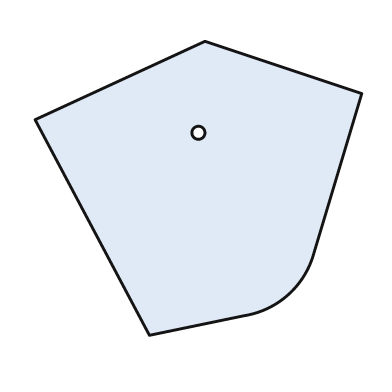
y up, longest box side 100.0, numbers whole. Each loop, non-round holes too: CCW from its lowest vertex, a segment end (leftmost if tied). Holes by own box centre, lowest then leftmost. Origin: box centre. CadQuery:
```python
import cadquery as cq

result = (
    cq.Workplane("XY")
    .moveTo(-15.0, -45.0)
    .lineTo(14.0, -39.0)
    .threePointArc((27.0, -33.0), (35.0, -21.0))
    .lineTo(50.0, 29.0)
    .lineTo(2.0, 45.0)
    .lineTo(-50.0, 21.0)
    .close()
    .moveTo(0.0, 17.0)
    .circle(2.0)
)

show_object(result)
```